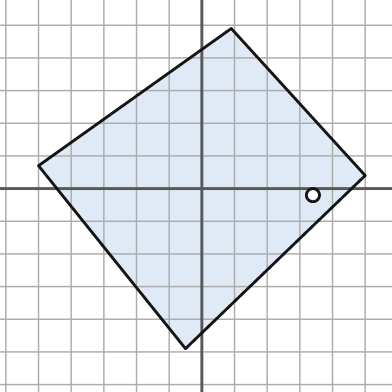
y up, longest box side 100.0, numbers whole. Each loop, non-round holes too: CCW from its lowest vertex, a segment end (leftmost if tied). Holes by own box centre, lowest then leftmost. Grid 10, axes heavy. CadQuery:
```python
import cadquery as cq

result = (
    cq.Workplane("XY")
    .moveTo(-5.0, -49.0)
    .lineTo(50.0, 4.0)
    .lineTo(9.0, 49.0)
    .lineTo(-50.0, 7.0)
    .close()
    .moveTo(34.0, -2.0)
    .circle(2.0)
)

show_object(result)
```